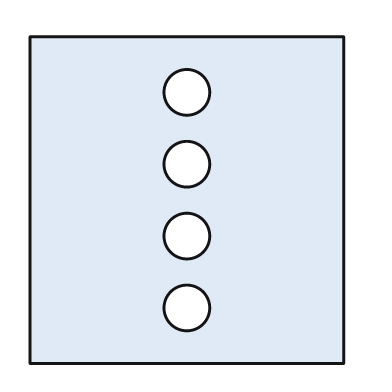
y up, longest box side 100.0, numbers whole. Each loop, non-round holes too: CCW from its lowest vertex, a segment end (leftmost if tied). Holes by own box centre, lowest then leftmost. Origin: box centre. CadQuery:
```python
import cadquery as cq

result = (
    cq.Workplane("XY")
    .moveTo(-48.0, -50.0)
    .lineTo(48.0, -50.0)
    .lineTo(48.0, 50.0)
    .lineTo(-48.0, 50.0)
    .close()
    .moveTo(0.0, -33.0)
    .circle(7.0)
    .moveTo(0.0, -11.0)
    .circle(7.0)
    .moveTo(0.0, 11.0)
    .circle(7.0)
    .moveTo(0.0, 33.0)
    .circle(7.0)
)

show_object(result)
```